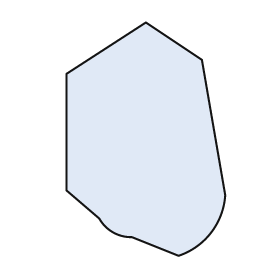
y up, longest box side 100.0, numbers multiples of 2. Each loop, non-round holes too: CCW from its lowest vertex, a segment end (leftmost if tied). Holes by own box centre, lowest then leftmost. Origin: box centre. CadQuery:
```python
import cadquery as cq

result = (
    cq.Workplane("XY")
    .moveTo(14.0, -50.0)
    .threePointArc((28.0, -40.0), (34.0, -24.0))
    .lineTo(24.0, 34.0)
    .lineTo(0.0, 50.0)
    .lineTo(-34.0, 28.0)
    .lineTo(-34.0, -22.0)
    .lineTo(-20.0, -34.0)
    .threePointArc((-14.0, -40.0), (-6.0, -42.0))
    .close()
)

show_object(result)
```